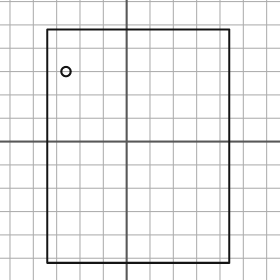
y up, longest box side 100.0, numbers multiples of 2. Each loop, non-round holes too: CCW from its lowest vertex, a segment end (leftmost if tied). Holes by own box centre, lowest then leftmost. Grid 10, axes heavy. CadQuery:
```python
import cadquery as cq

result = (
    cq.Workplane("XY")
    .moveTo(-34.0, -52.0)
    .lineTo(44.0, -52.0)
    .lineTo(44.0, 48.0)
    .lineTo(-34.0, 48.0)
    .close()
    .moveTo(-26.0, 30.0)
    .circle(2.0)
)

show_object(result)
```